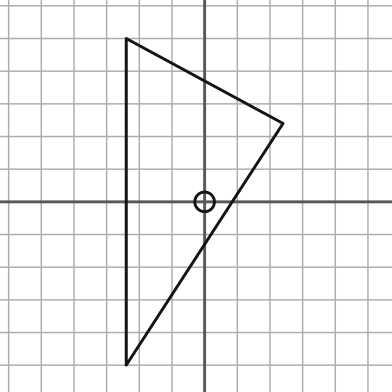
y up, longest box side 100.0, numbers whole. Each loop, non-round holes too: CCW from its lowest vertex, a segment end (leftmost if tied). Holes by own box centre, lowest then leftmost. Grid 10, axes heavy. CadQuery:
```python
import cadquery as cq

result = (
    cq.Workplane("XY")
    .moveTo(-24.0, -50.0)
    .lineTo(24.0, 24.0)
    .lineTo(-24.0, 50.0)
    .close()
    .moveTo(0.0, 0.0)
    .circle(3.0)
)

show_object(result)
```